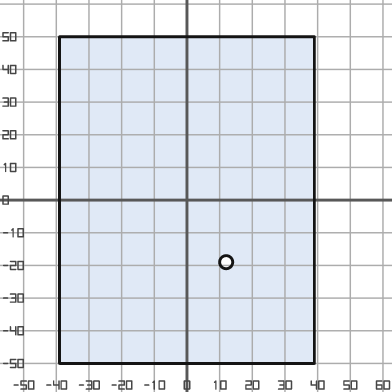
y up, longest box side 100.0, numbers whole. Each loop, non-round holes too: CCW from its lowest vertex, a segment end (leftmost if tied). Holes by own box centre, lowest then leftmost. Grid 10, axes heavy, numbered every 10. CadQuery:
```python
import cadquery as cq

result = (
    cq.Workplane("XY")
    .moveTo(-39.0, -50.0)
    .lineTo(39.0, -50.0)
    .lineTo(39.0, 50.0)
    .lineTo(-39.0, 50.0)
    .close()
    .moveTo(12.0, -19.0)
    .circle(2.0)
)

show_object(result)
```